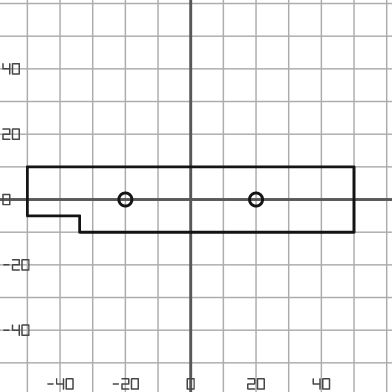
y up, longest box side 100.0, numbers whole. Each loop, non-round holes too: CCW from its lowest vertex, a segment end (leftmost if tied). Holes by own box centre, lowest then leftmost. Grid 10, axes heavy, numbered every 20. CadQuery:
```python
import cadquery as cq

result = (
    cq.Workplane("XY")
    .moveTo(-34.0, -10.0)
    .lineTo(50.0, -10.0)
    .lineTo(50.0, 10.0)
    .lineTo(-50.0, 10.0)
    .lineTo(-50.0, -5.0)
    .lineTo(-34.0, -5.0)
    .close()
    .moveTo(-20.0, 0.0)
    .circle(2.0)
    .moveTo(20.0, 0.0)
    .circle(2.0)
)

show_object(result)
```